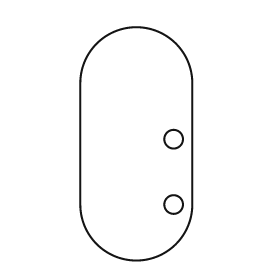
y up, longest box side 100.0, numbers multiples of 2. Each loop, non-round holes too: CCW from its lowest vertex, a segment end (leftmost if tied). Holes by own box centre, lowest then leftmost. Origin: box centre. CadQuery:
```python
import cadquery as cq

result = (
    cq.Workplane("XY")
    .moveTo(-24.0, -26.0)
    .threePointArc((0.0, -50.0), (24.0, -26.0))
    .lineTo(24.0, 26.0)
    .threePointArc((0.0, 50.0), (-24.0, 26.0))
    .close()
    .moveTo(16.0, -26.0)
    .circle(4.0)
    .moveTo(16.0, 2.0)
    .circle(4.0)
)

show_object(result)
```